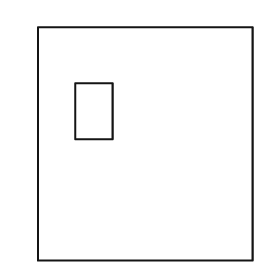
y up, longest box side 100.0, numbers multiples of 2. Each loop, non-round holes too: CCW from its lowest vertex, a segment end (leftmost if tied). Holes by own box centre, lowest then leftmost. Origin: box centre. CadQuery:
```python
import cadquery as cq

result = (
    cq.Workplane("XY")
    .moveTo(-46.0, -50.0)
    .lineTo(46.0, -50.0)
    .lineTo(46.0, 50.0)
    .lineTo(-46.0, 50.0)
    .close()
    .moveTo(-30.0, 2.0)
    .lineTo(-14.0, 2.0)
    .lineTo(-14.0, 26.0)
    .lineTo(-30.0, 26.0)
    .close()
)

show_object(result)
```